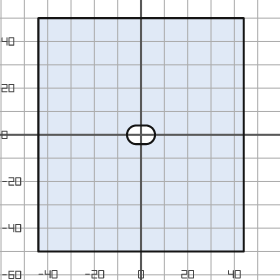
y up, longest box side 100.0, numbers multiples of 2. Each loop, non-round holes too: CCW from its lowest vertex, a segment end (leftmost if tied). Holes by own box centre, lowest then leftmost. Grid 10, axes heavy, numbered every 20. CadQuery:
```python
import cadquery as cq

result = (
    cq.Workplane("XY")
    .moveTo(-44.0, -50.0)
    .lineTo(44.0, -50.0)
    .lineTo(44.0, 50.0)
    .lineTo(-44.0, 50.0)
    .close()
    .moveTo(-2.0, -4.0)
    .lineTo(2.0, -4.0)
    .threePointArc((6.0, 0.0), (2.0, 4.0))
    .lineTo(-2.0, 4.0)
    .threePointArc((-6.0, 0.0), (-2.0, -4.0))
    .close()
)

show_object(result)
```